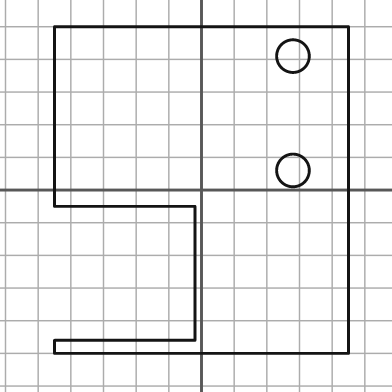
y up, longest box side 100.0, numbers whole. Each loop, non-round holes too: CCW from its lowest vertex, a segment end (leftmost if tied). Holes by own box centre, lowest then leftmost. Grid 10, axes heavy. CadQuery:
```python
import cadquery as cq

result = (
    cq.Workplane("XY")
    .moveTo(-45.0, -50.0)
    .lineTo(45.0, -50.0)
    .lineTo(45.0, 50.0)
    .lineTo(-45.0, 50.0)
    .lineTo(-45.0, -5.0)
    .lineTo(-2.0, -5.0)
    .lineTo(-2.0, -46.0)
    .lineTo(-45.0, -46.0)
    .close()
    .moveTo(28.0, 6.0)
    .circle(5.0)
    .moveTo(28.0, 41.0)
    .circle(5.0)
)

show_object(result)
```